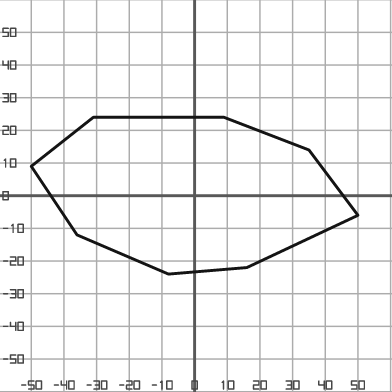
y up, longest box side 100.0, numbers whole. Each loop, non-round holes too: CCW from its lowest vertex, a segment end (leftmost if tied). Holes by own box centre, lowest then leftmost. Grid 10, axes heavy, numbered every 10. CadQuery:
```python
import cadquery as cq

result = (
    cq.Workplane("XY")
    .moveTo(-8.0, -24.0)
    .lineTo(16.0, -22.0)
    .lineTo(50.0, -6.0)
    .lineTo(35.0, 14.0)
    .lineTo(9.0, 24.0)
    .lineTo(-31.0, 24.0)
    .lineTo(-50.0, 9.0)
    .lineTo(-36.0, -12.0)
    .close()
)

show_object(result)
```